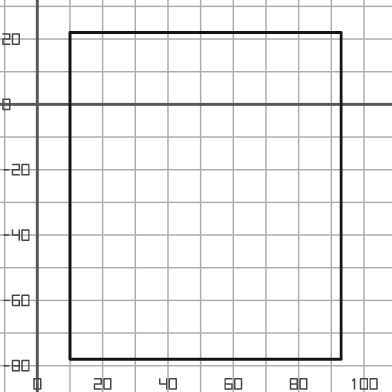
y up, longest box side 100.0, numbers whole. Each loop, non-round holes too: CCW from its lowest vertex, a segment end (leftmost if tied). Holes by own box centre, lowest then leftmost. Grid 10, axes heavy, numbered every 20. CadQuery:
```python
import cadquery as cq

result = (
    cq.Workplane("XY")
    .moveTo(10.0, -78.0)
    .lineTo(93.0, -78.0)
    .lineTo(93.0, 22.0)
    .lineTo(10.0, 22.0)
    .close()
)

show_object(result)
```